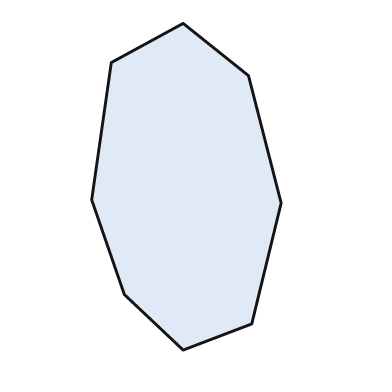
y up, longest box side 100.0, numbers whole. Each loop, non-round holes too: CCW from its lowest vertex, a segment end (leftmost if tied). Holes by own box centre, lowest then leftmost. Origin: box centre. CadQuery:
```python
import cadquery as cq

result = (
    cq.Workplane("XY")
    .moveTo(-1.0, -50.0)
    .lineTo(20.0, -42.0)
    .lineTo(29.0, -5.0)
    .lineTo(19.0, 34.0)
    .lineTo(-1.0, 50.0)
    .lineTo(-23.0, 38.0)
    .lineTo(-29.0, -4.0)
    .lineTo(-19.0, -33.0)
    .close()
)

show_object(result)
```